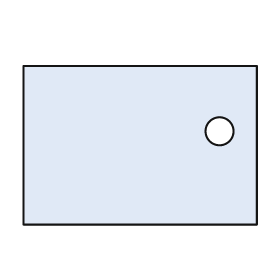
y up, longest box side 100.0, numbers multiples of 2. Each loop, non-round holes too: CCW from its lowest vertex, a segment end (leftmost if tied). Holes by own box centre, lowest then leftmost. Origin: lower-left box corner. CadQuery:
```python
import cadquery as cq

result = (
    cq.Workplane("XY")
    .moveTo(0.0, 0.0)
    .lineTo(100.0, 0.0)
    .lineTo(100.0, 68.0)
    .lineTo(0.0, 68.0)
    .close()
    .moveTo(84.0, 40.0)
    .circle(6.0)
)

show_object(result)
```